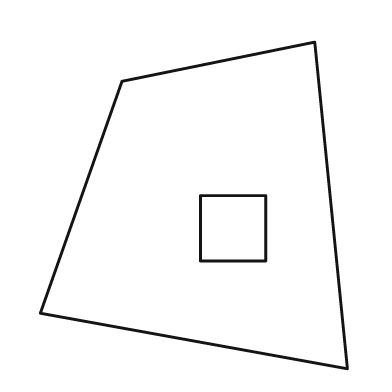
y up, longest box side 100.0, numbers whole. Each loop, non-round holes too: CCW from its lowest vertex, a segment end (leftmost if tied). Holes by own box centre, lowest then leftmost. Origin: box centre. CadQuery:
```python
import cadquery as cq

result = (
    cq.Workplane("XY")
    .moveTo(47.0, -50.0)
    .lineTo(37.0, 50.0)
    .lineTo(-22.0, 38.0)
    .lineTo(-47.0, -33.0)
    .close()
    .moveTo(2.0, -17.0)
    .lineTo(22.0, -17.0)
    .lineTo(22.0, 3.0)
    .lineTo(2.0, 3.0)
    .close()
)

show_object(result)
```